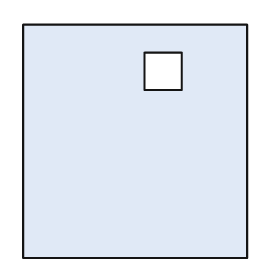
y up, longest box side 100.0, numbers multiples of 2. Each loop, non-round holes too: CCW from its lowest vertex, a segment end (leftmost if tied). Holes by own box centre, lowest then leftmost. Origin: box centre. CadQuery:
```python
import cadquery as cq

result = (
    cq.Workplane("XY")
    .moveTo(-48.0, -50.0)
    .lineTo(48.0, -50.0)
    .lineTo(48.0, 50.0)
    .lineTo(-48.0, 50.0)
    .close()
    .moveTo(4.0, 22.0)
    .lineTo(20.0, 22.0)
    .lineTo(20.0, 38.0)
    .lineTo(4.0, 38.0)
    .close()
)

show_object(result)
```